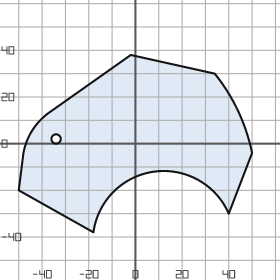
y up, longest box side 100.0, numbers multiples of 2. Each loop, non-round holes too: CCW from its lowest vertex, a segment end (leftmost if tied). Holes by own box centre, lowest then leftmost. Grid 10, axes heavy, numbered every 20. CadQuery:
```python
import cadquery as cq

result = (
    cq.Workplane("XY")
    .moveTo(-18.0, -38.0)
    .threePointArc((8.0, -12.0), (40.0, -30.0))
    .lineTo(50.0, -4.0)
    .threePointArc((44.0, 14.0), (34.0, 30.0))
    .lineTo(-2.0, 38.0)
    .lineTo(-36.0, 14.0)
    .threePointArc((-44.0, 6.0), (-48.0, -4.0))
    .lineTo(-50.0, -20.0)
    .close()
    .moveTo(-34.0, 2.0)
    .circle(2.0)
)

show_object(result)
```